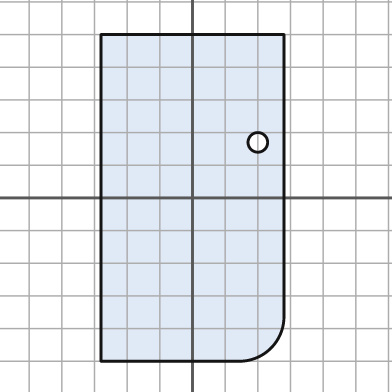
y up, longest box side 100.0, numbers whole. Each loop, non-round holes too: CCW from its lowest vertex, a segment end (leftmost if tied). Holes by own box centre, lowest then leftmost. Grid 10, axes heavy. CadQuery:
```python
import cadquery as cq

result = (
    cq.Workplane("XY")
    .moveTo(-28.0, -50.0)
    .lineTo(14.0, -50.0)
    .threePointArc((24.0, -46.0), (28.0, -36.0))
    .lineTo(28.0, 50.0)
    .lineTo(-28.0, 50.0)
    .close()
    .moveTo(20.0, 17.0)
    .circle(3.0)
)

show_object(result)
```